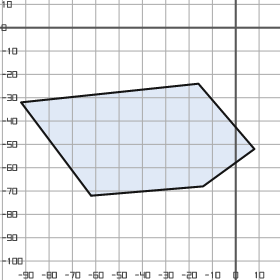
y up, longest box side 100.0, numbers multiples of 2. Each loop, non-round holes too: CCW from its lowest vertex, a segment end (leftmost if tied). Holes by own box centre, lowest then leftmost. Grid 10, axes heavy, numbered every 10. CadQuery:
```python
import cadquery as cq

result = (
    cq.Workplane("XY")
    .moveTo(-62.0, -72.0)
    .lineTo(-14.0, -68.0)
    .lineTo(8.0, -52.0)
    .lineTo(-16.0, -24.0)
    .lineTo(-92.0, -32.0)
    .close()
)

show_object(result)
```